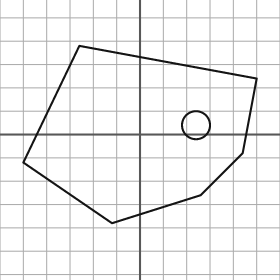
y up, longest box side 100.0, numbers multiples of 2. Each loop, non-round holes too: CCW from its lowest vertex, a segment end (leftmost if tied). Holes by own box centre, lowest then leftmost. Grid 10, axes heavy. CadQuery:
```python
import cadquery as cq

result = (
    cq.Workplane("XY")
    .moveTo(-12.0, -38.0)
    .lineTo(26.0, -26.0)
    .lineTo(44.0, -8.0)
    .lineTo(50.0, 24.0)
    .lineTo(-26.0, 38.0)
    .lineTo(-50.0, -12.0)
    .close()
    .moveTo(24.0, 4.0)
    .circle(6.0)
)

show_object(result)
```